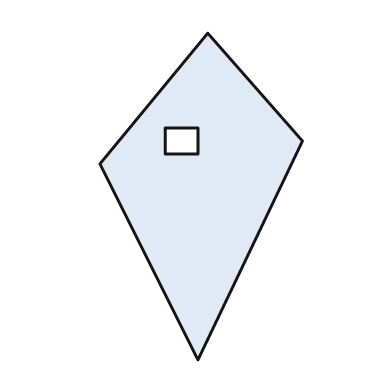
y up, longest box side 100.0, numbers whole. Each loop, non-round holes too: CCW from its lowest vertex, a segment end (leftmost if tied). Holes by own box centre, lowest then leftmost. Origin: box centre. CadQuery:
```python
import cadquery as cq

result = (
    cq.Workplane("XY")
    .moveTo(-1.0, -50.0)
    .lineTo(31.0, 17.0)
    .lineTo(2.0, 50.0)
    .lineTo(-31.0, 10.0)
    .close()
    .moveTo(-11.0, 13.0)
    .lineTo(-1.0, 13.0)
    .lineTo(-1.0, 21.0)
    .lineTo(-11.0, 21.0)
    .close()
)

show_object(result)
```